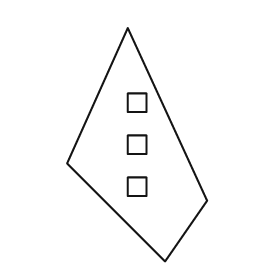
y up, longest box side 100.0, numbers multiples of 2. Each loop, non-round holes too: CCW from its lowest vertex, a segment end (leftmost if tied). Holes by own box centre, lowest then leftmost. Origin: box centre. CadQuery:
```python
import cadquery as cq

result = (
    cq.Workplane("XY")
    .moveTo(12.0, -50.0)
    .lineTo(30.0, -24.0)
    .lineTo(-4.0, 50.0)
    .lineTo(-30.0, -8.0)
    .close()
    .moveTo(-4.0, -22.0)
    .lineTo(4.0, -22.0)
    .lineTo(4.0, -14.0)
    .lineTo(-4.0, -14.0)
    .close()
    .moveTo(-4.0, -4.0)
    .lineTo(4.0, -4.0)
    .lineTo(4.0, 4.0)
    .lineTo(-4.0, 4.0)
    .close()
    .moveTo(-4.0, 14.0)
    .lineTo(4.0, 14.0)
    .lineTo(4.0, 22.0)
    .lineTo(-4.0, 22.0)
    .close()
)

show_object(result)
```